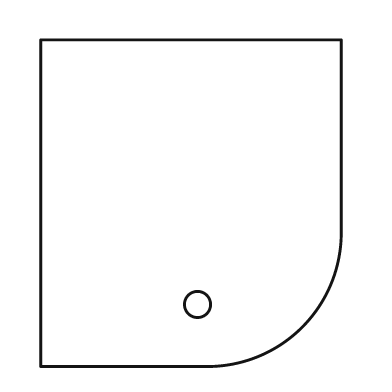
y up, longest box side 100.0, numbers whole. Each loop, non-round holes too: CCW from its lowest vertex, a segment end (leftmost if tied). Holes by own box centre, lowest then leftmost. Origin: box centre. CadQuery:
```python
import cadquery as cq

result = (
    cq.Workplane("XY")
    .moveTo(-46.0, -50.0)
    .lineTo(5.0, -50.0)
    .threePointArc((34.0, -38.0), (46.0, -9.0))
    .lineTo(46.0, 50.0)
    .lineTo(-46.0, 50.0)
    .close()
    .moveTo(2.0, -31.0)
    .circle(4.0)
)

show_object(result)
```